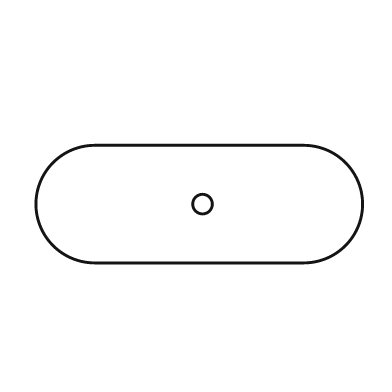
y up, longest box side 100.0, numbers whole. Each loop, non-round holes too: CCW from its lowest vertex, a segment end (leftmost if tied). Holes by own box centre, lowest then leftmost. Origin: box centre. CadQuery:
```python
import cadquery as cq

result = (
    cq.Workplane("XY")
    .moveTo(-32.0, -18.0)
    .lineTo(32.0, -18.0)
    .threePointArc((50.0, 0.0), (32.0, 18.0))
    .lineTo(-32.0, 18.0)
    .threePointArc((-50.0, 0.0), (-32.0, -18.0))
    .close()
    .moveTo(1.0, 0.0)
    .circle(3.0)
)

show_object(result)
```